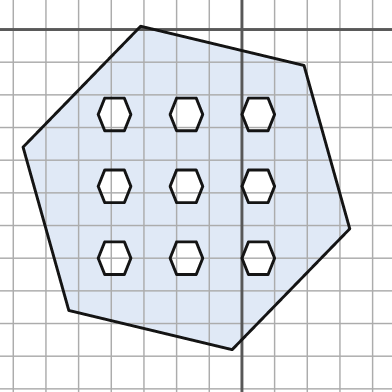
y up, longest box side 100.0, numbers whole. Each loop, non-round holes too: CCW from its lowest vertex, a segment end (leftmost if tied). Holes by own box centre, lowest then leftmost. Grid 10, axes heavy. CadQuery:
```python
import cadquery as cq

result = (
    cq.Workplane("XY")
    .moveTo(-3.0, -98.0)
    .lineTo(33.0, -61.0)
    .lineTo(19.0, -11.0)
    .lineTo(-31.0, 1.0)
    .lineTo(-67.0, -36.0)
    .lineTo(-53.0, -86.0)
    .close()
    .moveTo(-42.0, -75.0)
    .lineTo(-36.0, -75.0)
    .lineTo(-34.0, -70.0)
    .lineTo(-36.0, -65.0)
    .lineTo(-42.0, -65.0)
    .lineTo(-44.0, -70.0)
    .close()
    .moveTo(-20.0, -75.0)
    .lineTo(-14.0, -75.0)
    .lineTo(-12.0, -70.0)
    .lineTo(-14.0, -65.0)
    .lineTo(-20.0, -65.0)
    .lineTo(-22.0, -70.0)
    .close()
    .moveTo(2.0, -75.0)
    .lineTo(8.0, -75.0)
    .lineTo(10.0, -70.0)
    .lineTo(8.0, -65.0)
    .lineTo(2.0, -65.0)
    .lineTo(0.0, -70.0)
    .close()
    .moveTo(-42.0, -53.0)
    .lineTo(-36.0, -53.0)
    .lineTo(-34.0, -48.0)
    .lineTo(-36.0, -43.0)
    .lineTo(-42.0, -43.0)
    .lineTo(-44.0, -48.0)
    .close()
    .moveTo(-20.0, -53.0)
    .lineTo(-14.0, -53.0)
    .lineTo(-12.0, -48.0)
    .lineTo(-14.0, -43.0)
    .lineTo(-20.0, -43.0)
    .lineTo(-22.0, -48.0)
    .close()
    .moveTo(2.0, -53.0)
    .lineTo(8.0, -53.0)
    .lineTo(10.0, -48.0)
    .lineTo(8.0, -43.0)
    .lineTo(2.0, -43.0)
    .lineTo(0.0, -48.0)
    .close()
    .moveTo(-42.0, -31.0)
    .lineTo(-36.0, -31.0)
    .lineTo(-34.0, -26.0)
    .lineTo(-36.0, -21.0)
    .lineTo(-42.0, -21.0)
    .lineTo(-44.0, -26.0)
    .close()
    .moveTo(-20.0, -31.0)
    .lineTo(-14.0, -31.0)
    .lineTo(-12.0, -26.0)
    .lineTo(-14.0, -21.0)
    .lineTo(-20.0, -21.0)
    .lineTo(-22.0, -26.0)
    .close()
    .moveTo(2.0, -31.0)
    .lineTo(8.0, -31.0)
    .lineTo(10.0, -26.0)
    .lineTo(8.0, -21.0)
    .lineTo(2.0, -21.0)
    .lineTo(0.0, -26.0)
    .close()
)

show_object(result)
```